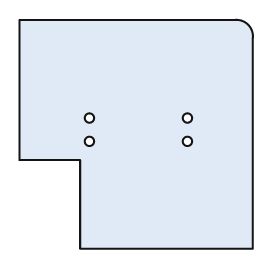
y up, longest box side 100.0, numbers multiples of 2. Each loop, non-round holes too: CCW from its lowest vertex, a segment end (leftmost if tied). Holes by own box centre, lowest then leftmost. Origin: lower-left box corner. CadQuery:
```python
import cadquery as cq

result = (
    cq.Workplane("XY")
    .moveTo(26.0, 0.0)
    .lineTo(100.0, 0.0)
    .lineTo(100.0, 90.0)
    .threePointArc((98.0, 96.0), (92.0, 98.0))
    .lineTo(0.0, 98.0)
    .lineTo(0.0, 38.0)
    .lineTo(26.0, 38.0)
    .close()
    .moveTo(30.0, 46.0)
    .circle(2.0)
    .moveTo(72.0, 46.0)
    .circle(2.0)
    .moveTo(30.0, 56.0)
    .circle(2.0)
    .moveTo(72.0, 56.0)
    .circle(2.0)
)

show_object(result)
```